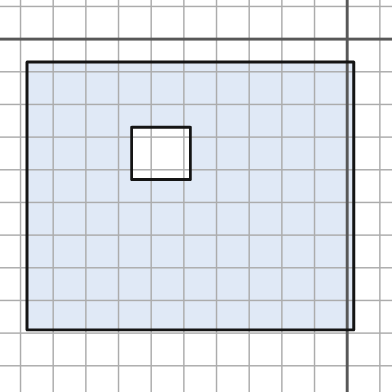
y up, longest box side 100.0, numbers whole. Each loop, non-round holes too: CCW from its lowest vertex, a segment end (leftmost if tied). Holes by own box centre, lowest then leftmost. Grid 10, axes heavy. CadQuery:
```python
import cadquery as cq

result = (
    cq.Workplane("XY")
    .moveTo(-98.0, -89.0)
    .lineTo(2.0, -89.0)
    .lineTo(2.0, -7.0)
    .lineTo(-98.0, -7.0)
    .close()
    .moveTo(-66.0, -43.0)
    .lineTo(-48.0, -43.0)
    .lineTo(-48.0, -27.0)
    .lineTo(-66.0, -27.0)
    .close()
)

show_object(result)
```